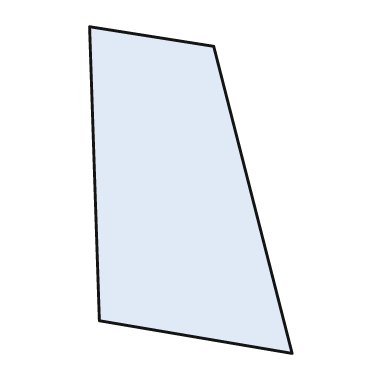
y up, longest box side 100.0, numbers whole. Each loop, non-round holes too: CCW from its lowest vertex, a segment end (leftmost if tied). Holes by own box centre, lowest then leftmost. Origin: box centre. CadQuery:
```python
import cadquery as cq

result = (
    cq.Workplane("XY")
    .moveTo(31.0, -50.0)
    .lineTo(7.0, 44.0)
    .lineTo(-31.0, 50.0)
    .lineTo(-28.0, -40.0)
    .close()
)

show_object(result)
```